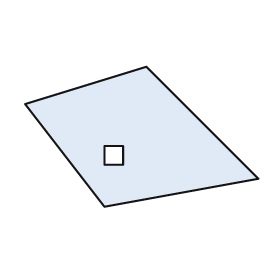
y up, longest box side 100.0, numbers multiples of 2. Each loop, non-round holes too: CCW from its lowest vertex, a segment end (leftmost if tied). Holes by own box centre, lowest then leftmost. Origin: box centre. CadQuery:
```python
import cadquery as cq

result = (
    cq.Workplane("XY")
    .moveTo(-16.0, -30.0)
    .lineTo(50.0, -18.0)
    .lineTo(2.0, 30.0)
    .lineTo(-50.0, 14.0)
    .close()
    .moveTo(-16.0, -12.0)
    .lineTo(-8.0, -12.0)
    .lineTo(-8.0, -4.0)
    .lineTo(-16.0, -4.0)
    .close()
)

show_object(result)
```